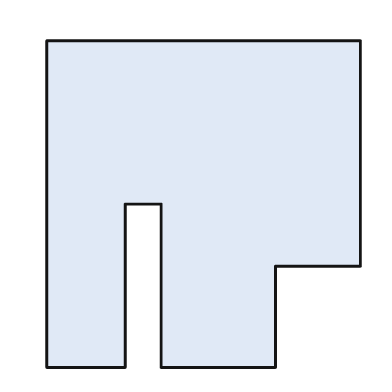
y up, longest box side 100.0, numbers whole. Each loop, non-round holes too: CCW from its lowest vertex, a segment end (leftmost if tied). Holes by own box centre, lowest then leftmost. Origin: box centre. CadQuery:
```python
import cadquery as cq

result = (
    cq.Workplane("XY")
    .moveTo(-48.0, -50.0)
    .lineTo(-24.0, -50.0)
    .lineTo(-24.0, 0.0)
    .lineTo(-13.0, 0.0)
    .lineTo(-13.0, -50.0)
    .lineTo(22.0, -50.0)
    .lineTo(22.0, -19.0)
    .lineTo(48.0, -19.0)
    .lineTo(48.0, 50.0)
    .lineTo(-48.0, 50.0)
    .close()
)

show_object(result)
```